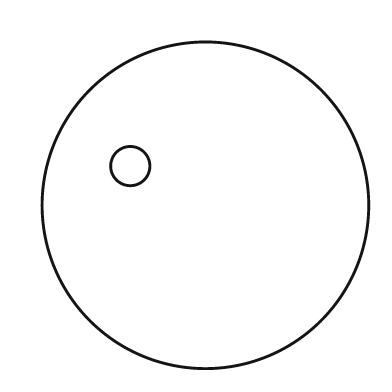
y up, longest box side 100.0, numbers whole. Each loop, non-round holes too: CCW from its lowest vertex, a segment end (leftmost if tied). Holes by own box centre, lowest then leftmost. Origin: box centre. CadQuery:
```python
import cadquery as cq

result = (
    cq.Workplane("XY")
    .moveTo(0.0, 0.0)
    .circle(50.0)
    .moveTo(-23.0, 12.0)
    .circle(6.0)
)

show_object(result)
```